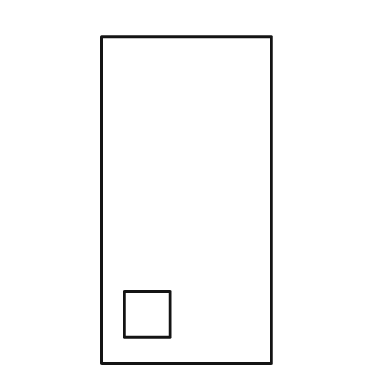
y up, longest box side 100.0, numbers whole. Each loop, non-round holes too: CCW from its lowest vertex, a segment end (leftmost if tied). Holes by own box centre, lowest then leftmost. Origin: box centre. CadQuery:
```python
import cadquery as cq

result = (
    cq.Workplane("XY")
    .moveTo(-26.0, -50.0)
    .lineTo(26.0, -50.0)
    .lineTo(26.0, 50.0)
    .lineTo(-26.0, 50.0)
    .close()
    .moveTo(-19.0, -42.0)
    .lineTo(-5.0, -42.0)
    .lineTo(-5.0, -28.0)
    .lineTo(-19.0, -28.0)
    .close()
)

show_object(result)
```